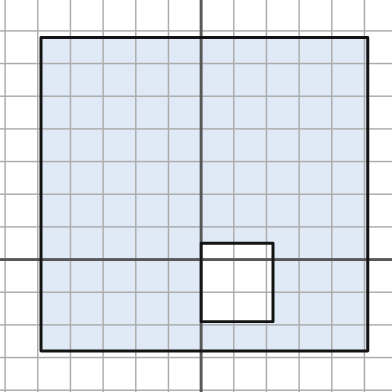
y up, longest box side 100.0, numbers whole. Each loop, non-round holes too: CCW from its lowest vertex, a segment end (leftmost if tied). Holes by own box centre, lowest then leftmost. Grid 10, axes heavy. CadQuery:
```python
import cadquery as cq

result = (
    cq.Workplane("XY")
    .moveTo(-49.0, -28.0)
    .lineTo(51.0, -28.0)
    .lineTo(51.0, 68.0)
    .lineTo(-49.0, 68.0)
    .close()
    .moveTo(0.0, -19.0)
    .lineTo(22.0, -19.0)
    .lineTo(22.0, 5.0)
    .lineTo(0.0, 5.0)
    .close()
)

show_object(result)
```